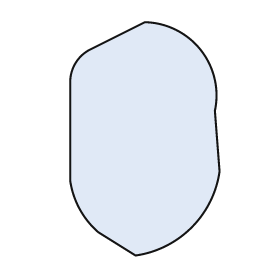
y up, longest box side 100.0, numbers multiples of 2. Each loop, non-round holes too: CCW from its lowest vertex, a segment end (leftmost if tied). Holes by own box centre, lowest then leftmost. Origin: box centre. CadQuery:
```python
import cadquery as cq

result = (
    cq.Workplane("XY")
    .moveTo(-4.0, -50.0)
    .threePointArc((20.0, -38.0), (32.0, -14.0))
    .lineTo(30.0, 12.0)
    .threePointArc((24.0, 38.0), (0.0, 50.0))
    .lineTo(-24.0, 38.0)
    .threePointArc((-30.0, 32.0), (-32.0, 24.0))
    .lineTo(-32.0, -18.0)
    .threePointArc((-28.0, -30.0), (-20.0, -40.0))
    .close()
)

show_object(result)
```